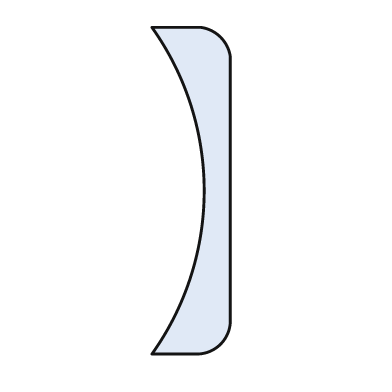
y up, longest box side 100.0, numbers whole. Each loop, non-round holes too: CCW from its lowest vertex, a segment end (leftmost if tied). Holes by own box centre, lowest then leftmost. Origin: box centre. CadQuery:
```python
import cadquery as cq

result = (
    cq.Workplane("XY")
    .moveTo(-12.0, -50.0)
    .lineTo(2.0, -50.0)
    .threePointArc((9.0, -47.0), (12.0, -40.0))
    .lineTo(12.0, 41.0)
    .threePointArc((9.0, 47.0), (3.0, 50.0))
    .lineTo(-12.0, 50.0)
    .threePointArc((4.0, 0.0), (-12.0, -50.0))
    .close()
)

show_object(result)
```